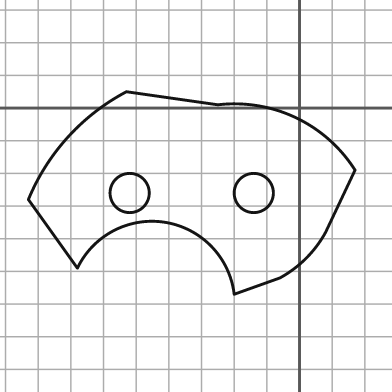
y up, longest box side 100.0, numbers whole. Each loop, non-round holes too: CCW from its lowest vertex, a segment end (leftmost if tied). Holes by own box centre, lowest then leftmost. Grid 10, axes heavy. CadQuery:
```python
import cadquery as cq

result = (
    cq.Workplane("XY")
    .moveTo(-20.0, -57.0)
    .lineTo(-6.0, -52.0)
    .threePointArc((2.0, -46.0), (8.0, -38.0))
    .lineTo(17.0, -19.0)
    .threePointArc((-1.0, -3.0), (-25.0, 1.0))
    .lineTo(-53.0, 5.0)
    .threePointArc((-71.0, -9.0), (-83.0, -28.0))
    .lineTo(-68.0, -49.0)
    .threePointArc((-41.0, -35.0), (-20.0, -57.0))
    .close()
    .moveTo(-52.0, -26.0)
    .circle(6.0)
    .moveTo(-14.0, -26.0)
    .circle(6.0)
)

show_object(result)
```